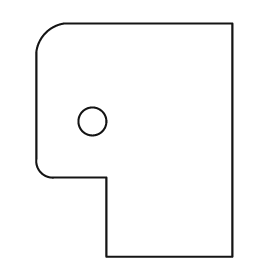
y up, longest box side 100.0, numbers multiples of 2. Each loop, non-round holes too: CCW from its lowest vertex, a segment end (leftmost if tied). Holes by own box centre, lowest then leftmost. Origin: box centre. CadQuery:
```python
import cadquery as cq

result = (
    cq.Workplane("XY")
    .moveTo(-12.0, -50.0)
    .lineTo(42.0, -50.0)
    .lineTo(42.0, 50.0)
    .lineTo(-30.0, 50.0)
    .threePointArc((-38.0, 46.0), (-42.0, 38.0))
    .lineTo(-42.0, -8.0)
    .threePointArc((-40.0, -14.0), (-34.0, -16.0))
    .lineTo(-12.0, -16.0)
    .close()
    .moveTo(-18.0, 8.0)
    .circle(6.0)
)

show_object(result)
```